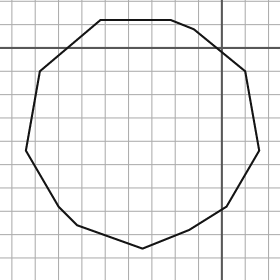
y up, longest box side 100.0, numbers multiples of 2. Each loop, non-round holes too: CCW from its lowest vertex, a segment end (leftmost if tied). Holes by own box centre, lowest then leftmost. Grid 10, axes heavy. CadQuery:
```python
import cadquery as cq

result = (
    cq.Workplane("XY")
    .moveTo(-34.0, -86.0)
    .lineTo(-14.0, -78.0)
    .lineTo(2.0, -68.0)
    .lineTo(16.0, -44.0)
    .lineTo(10.0, -10.0)
    .lineTo(-12.0, 8.0)
    .lineTo(-22.0, 12.0)
    .lineTo(-52.0, 12.0)
    .lineTo(-78.0, -10.0)
    .lineTo(-84.0, -44.0)
    .lineTo(-70.0, -68.0)
    .lineTo(-62.0, -76.0)
    .close()
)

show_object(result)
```